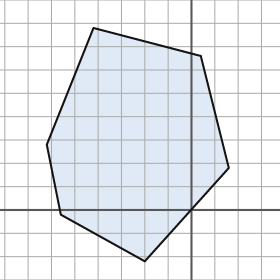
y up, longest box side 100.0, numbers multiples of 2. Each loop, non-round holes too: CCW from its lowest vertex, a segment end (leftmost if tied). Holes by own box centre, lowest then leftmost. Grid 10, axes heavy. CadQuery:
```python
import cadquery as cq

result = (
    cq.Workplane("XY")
    .moveTo(-20.0, -22.0)
    .lineTo(16.0, 18.0)
    .lineTo(4.0, 66.0)
    .lineTo(-42.0, 78.0)
    .lineTo(-62.0, 28.0)
    .lineTo(-56.0, -2.0)
    .close()
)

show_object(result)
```